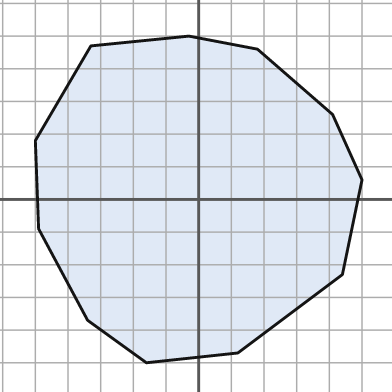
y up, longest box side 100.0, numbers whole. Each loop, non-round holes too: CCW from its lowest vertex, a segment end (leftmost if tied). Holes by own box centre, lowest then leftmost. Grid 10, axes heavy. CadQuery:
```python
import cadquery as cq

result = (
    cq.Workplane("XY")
    .moveTo(-16.0, -50.0)
    .lineTo(12.0, -47.0)
    .lineTo(44.0, -23.0)
    .lineTo(50.0, 6.0)
    .lineTo(41.0, 26.0)
    .lineTo(18.0, 46.0)
    .lineTo(-3.0, 50.0)
    .lineTo(-33.0, 47.0)
    .lineTo(-50.0, 18.0)
    .lineTo(-49.0, -9.0)
    .lineTo(-34.0, -37.0)
    .close()
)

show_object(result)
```